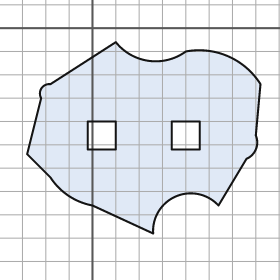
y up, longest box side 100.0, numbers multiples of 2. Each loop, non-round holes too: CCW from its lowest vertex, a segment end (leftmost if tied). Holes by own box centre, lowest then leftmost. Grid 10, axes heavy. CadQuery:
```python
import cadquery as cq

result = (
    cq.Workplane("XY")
    .moveTo(26.0, -88.0)
    .threePointArc((36.0, -72.0), (54.0, -76.0))
    .lineTo(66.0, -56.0)
    .threePointArc((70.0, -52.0), (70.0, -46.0))
    .lineTo(72.0, -24.0)
    .threePointArc((58.0, -12.0), (40.0, -10.0))
    .threePointArc((24.0, -14.0), (10.0, -6.0))
    .lineTo(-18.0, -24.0)
    .threePointArc((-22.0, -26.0), (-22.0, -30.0))
    .lineTo(-28.0, -54.0)
    .lineTo(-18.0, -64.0)
    .threePointArc((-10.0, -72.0), (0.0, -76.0))
    .close()
    .moveTo(-2.0, -52.0)
    .lineTo(10.0, -52.0)
    .lineTo(10.0, -40.0)
    .lineTo(-2.0, -40.0)
    .close()
    .moveTo(34.0, -52.0)
    .lineTo(46.0, -52.0)
    .lineTo(46.0, -40.0)
    .lineTo(34.0, -40.0)
    .close()
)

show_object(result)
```